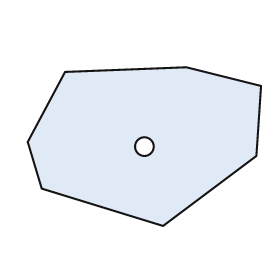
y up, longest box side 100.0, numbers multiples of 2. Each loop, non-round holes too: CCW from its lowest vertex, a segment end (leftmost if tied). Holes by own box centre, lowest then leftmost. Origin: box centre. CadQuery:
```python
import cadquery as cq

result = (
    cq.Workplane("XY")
    .moveTo(8.0, -34.0)
    .lineTo(48.0, -4.0)
    .lineTo(50.0, 26.0)
    .lineTo(18.0, 34.0)
    .lineTo(-34.0, 32.0)
    .lineTo(-50.0, 2.0)
    .lineTo(-44.0, -18.0)
    .close()
    .moveTo(0.0, 0.0)
    .circle(4.0)
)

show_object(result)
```